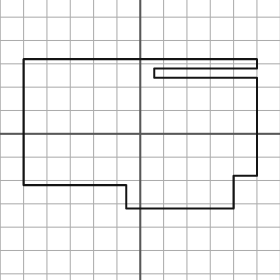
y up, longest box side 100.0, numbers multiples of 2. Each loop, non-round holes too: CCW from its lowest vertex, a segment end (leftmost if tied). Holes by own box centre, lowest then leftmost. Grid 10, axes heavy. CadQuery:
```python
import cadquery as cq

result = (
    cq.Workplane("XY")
    .moveTo(-6.0, -32.0)
    .lineTo(40.0, -32.0)
    .lineTo(40.0, -18.0)
    .lineTo(50.0, -18.0)
    .lineTo(50.0, 24.0)
    .lineTo(6.0, 24.0)
    .lineTo(6.0, 28.0)
    .lineTo(50.0, 28.0)
    .lineTo(50.0, 32.0)
    .lineTo(-50.0, 32.0)
    .lineTo(-50.0, -22.0)
    .lineTo(-6.0, -22.0)
    .close()
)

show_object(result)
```